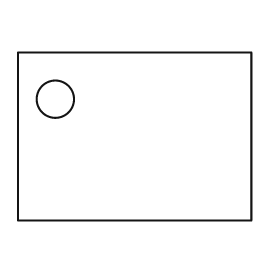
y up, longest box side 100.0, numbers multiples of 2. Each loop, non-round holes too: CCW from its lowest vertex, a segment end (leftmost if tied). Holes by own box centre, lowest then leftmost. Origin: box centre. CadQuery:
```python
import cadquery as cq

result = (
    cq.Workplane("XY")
    .moveTo(-50.0, -36.0)
    .lineTo(50.0, -36.0)
    .lineTo(50.0, 36.0)
    .lineTo(-50.0, 36.0)
    .close()
    .moveTo(-34.0, 16.0)
    .circle(8.0)
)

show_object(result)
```